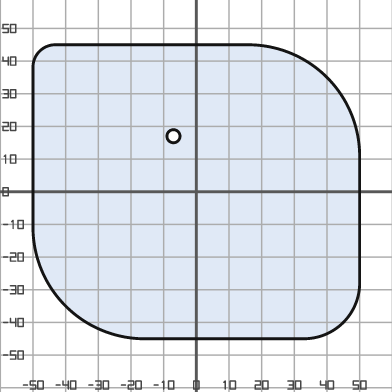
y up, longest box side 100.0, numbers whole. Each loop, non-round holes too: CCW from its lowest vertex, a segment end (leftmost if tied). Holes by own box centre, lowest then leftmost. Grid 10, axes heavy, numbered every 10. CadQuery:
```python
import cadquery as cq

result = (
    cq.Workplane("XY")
    .moveTo(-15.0, -45.0)
    .lineTo(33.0, -45.0)
    .threePointArc((45.0, -40.0), (50.0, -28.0))
    .lineTo(50.0, 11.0)
    .threePointArc((40.0, 35.0), (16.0, 45.0))
    .lineTo(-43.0, 45.0)
    .threePointArc((-48.0, 43.0), (-50.0, 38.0))
    .lineTo(-50.0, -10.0)
    .threePointArc((-40.0, -35.0), (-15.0, -45.0))
    .close()
    .moveTo(-7.0, 17.0)
    .circle(2.0)
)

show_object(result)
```